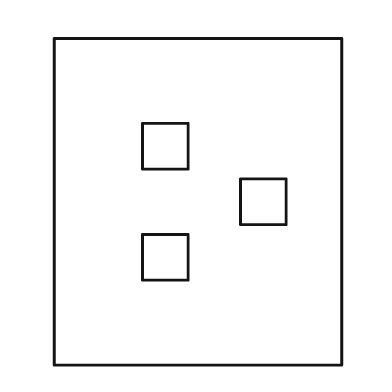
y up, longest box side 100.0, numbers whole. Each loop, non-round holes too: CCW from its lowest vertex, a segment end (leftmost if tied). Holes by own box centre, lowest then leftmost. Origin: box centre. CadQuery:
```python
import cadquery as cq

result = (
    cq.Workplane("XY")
    .moveTo(-44.0, -50.0)
    .lineTo(44.0, -50.0)
    .lineTo(44.0, 50.0)
    .lineTo(-44.0, 50.0)
    .close()
    .moveTo(-17.0, -24.0)
    .lineTo(-3.0, -24.0)
    .lineTo(-3.0, -10.0)
    .lineTo(-17.0, -10.0)
    .close()
    .moveTo(13.0, -7.0)
    .lineTo(27.0, -7.0)
    .lineTo(27.0, 7.0)
    .lineTo(13.0, 7.0)
    .close()
    .moveTo(-17.0, 10.0)
    .lineTo(-3.0, 10.0)
    .lineTo(-3.0, 24.0)
    .lineTo(-17.0, 24.0)
    .close()
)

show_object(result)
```